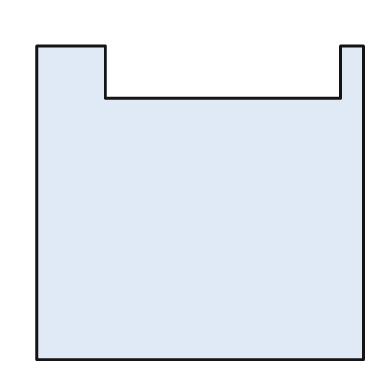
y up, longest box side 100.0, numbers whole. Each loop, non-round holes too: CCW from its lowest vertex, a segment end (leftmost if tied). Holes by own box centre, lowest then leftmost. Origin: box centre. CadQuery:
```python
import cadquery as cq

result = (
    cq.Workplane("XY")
    .moveTo(-50.0, -48.0)
    .lineTo(50.0, -48.0)
    .lineTo(50.0, 48.0)
    .lineTo(43.0, 48.0)
    .lineTo(43.0, 32.0)
    .lineTo(-29.0, 32.0)
    .lineTo(-29.0, 48.0)
    .lineTo(-50.0, 48.0)
    .close()
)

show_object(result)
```